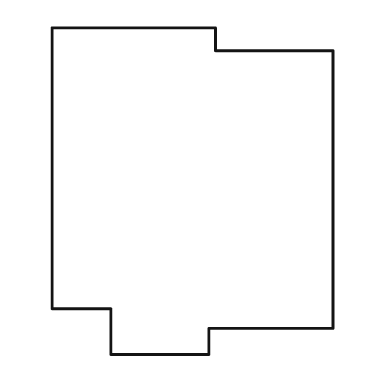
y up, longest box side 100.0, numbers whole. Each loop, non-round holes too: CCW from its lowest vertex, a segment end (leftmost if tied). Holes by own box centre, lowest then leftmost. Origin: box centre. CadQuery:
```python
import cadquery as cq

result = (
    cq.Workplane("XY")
    .moveTo(-25.0, -50.0)
    .lineTo(5.0, -50.0)
    .lineTo(5.0, -42.0)
    .lineTo(43.0, -42.0)
    .lineTo(43.0, 43.0)
    .lineTo(7.0, 43.0)
    .lineTo(7.0, 50.0)
    .lineTo(-43.0, 50.0)
    .lineTo(-43.0, -36.0)
    .lineTo(-25.0, -36.0)
    .close()
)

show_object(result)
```